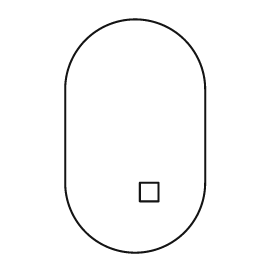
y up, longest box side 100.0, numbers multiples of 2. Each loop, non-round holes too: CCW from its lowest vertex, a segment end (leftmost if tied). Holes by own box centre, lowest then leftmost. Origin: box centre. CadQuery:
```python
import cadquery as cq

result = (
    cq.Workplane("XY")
    .moveTo(-30.0, -20.0)
    .threePointArc((0.0, -50.0), (30.0, -20.0))
    .lineTo(30.0, 20.0)
    .threePointArc((0.0, 50.0), (-30.0, 20.0))
    .close()
    .moveTo(2.0, -28.0)
    .lineTo(10.0, -28.0)
    .lineTo(10.0, -20.0)
    .lineTo(2.0, -20.0)
    .close()
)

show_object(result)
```